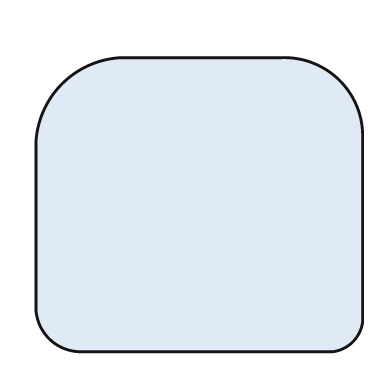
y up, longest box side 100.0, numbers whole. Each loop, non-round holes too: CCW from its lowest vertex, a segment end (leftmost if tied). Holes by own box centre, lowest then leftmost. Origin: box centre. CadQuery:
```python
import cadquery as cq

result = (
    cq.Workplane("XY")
    .moveTo(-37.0, -45.0)
    .lineTo(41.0, -45.0)
    .threePointArc((47.0, -42.0), (50.0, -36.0))
    .lineTo(50.0, 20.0)
    .threePointArc((43.0, 38.0), (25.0, 45.0))
    .lineTo(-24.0, 45.0)
    .threePointArc((-42.0, 37.0), (-50.0, 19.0))
    .lineTo(-50.0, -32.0)
    .threePointArc((-46.0, -41.0), (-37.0, -45.0))
    .close()
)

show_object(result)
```